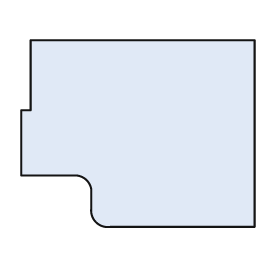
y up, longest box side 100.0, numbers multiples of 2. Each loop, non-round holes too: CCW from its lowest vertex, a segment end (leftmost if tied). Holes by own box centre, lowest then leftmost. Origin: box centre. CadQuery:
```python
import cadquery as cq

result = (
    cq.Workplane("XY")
    .moveTo(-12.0, -40.0)
    .lineTo(50.0, -40.0)
    .lineTo(50.0, 40.0)
    .lineTo(-46.0, 40.0)
    .lineTo(-46.0, 10.0)
    .lineTo(-50.0, 10.0)
    .lineTo(-50.0, -18.0)
    .lineTo(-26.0, -18.0)
    .threePointArc((-22.0, -20.0), (-20.0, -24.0))
    .lineTo(-20.0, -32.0)
    .threePointArc((-18.0, -38.0), (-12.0, -40.0))
    .close()
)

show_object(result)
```